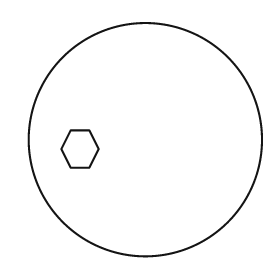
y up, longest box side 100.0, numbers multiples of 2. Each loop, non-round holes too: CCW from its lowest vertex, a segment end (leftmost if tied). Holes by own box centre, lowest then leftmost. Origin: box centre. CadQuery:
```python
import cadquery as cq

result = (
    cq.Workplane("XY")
    .moveTo(0.0, 0.0)
    .circle(50.0)
    .moveTo(-32.0, -12.0)
    .lineTo(-24.0, -12.0)
    .lineTo(-20.0, -4.0)
    .lineTo(-24.0, 4.0)
    .lineTo(-32.0, 4.0)
    .lineTo(-36.0, -4.0)
    .close()
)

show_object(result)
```